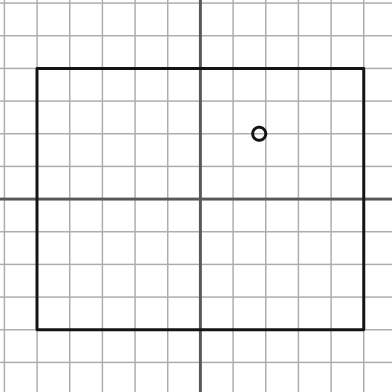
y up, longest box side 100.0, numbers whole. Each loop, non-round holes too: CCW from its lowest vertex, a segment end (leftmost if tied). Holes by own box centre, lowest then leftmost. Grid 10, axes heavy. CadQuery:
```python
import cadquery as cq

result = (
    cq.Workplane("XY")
    .moveTo(-50.0, -40.0)
    .lineTo(50.0, -40.0)
    .lineTo(50.0, 40.0)
    .lineTo(-50.0, 40.0)
    .close()
    .moveTo(18.0, 20.0)
    .circle(2.0)
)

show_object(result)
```